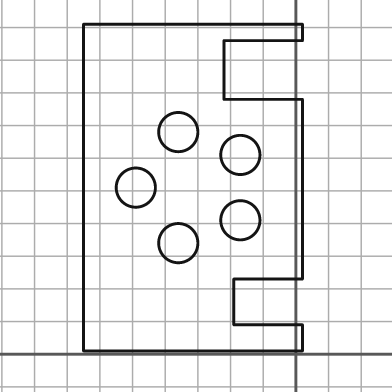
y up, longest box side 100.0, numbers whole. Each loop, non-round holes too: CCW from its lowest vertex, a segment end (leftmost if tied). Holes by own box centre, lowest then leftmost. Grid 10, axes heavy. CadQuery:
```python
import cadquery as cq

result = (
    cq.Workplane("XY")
    .moveTo(-65.0, 1.0)
    .lineTo(2.0, 1.0)
    .lineTo(2.0, 9.0)
    .lineTo(-19.0, 9.0)
    .lineTo(-19.0, 23.0)
    .lineTo(2.0, 23.0)
    .lineTo(2.0, 78.0)
    .lineTo(-22.0, 78.0)
    .lineTo(-22.0, 96.0)
    .lineTo(2.0, 96.0)
    .lineTo(2.0, 101.0)
    .lineTo(-65.0, 101.0)
    .close()
    .moveTo(-36.0, 34.0)
    .circle(6.0)
    .moveTo(-17.0, 41.0)
    .circle(6.0)
    .moveTo(-49.0, 51.0)
    .circle(6.0)
    .moveTo(-17.0, 61.0)
    .circle(6.0)
    .moveTo(-36.0, 68.0)
    .circle(6.0)
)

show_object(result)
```